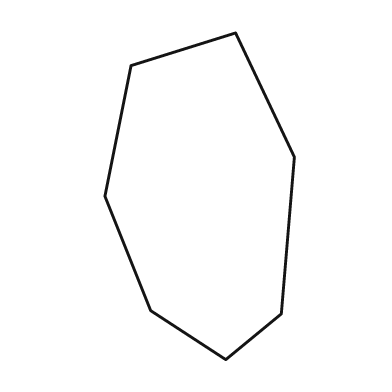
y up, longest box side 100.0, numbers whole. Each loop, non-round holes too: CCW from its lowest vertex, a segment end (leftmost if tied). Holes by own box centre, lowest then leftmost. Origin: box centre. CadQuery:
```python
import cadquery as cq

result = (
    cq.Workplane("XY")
    .moveTo(8.0, -50.0)
    .lineTo(25.0, -36.0)
    .lineTo(29.0, 12.0)
    .lineTo(11.0, 50.0)
    .lineTo(-21.0, 40.0)
    .lineTo(-29.0, 0.0)
    .lineTo(-15.0, -35.0)
    .close()
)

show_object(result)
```